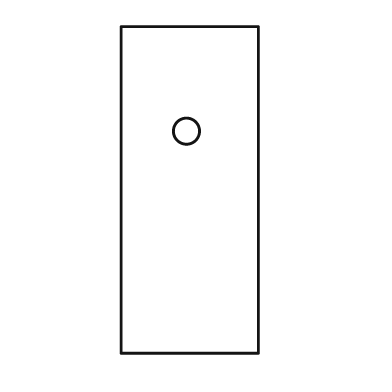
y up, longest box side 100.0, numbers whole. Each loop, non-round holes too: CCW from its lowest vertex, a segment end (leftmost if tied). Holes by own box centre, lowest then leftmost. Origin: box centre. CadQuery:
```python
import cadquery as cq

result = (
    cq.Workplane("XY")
    .moveTo(-21.0, -50.0)
    .lineTo(21.0, -50.0)
    .lineTo(21.0, 50.0)
    .lineTo(-21.0, 50.0)
    .close()
    .moveTo(-1.0, 18.0)
    .circle(4.0)
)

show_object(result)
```